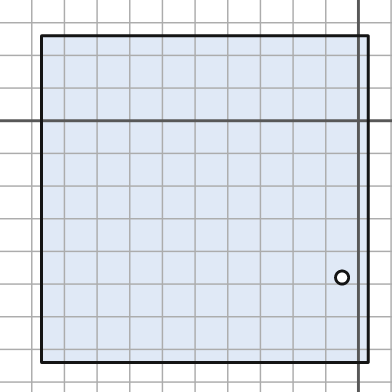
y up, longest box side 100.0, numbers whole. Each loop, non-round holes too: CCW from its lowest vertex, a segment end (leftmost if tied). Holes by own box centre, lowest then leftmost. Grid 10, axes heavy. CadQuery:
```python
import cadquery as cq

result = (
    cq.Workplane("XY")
    .moveTo(-97.0, -74.0)
    .lineTo(3.0, -74.0)
    .lineTo(3.0, 26.0)
    .lineTo(-97.0, 26.0)
    .close()
    .moveTo(-5.0, -48.0)
    .circle(2.0)
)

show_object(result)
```